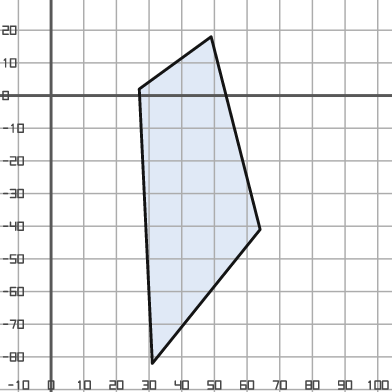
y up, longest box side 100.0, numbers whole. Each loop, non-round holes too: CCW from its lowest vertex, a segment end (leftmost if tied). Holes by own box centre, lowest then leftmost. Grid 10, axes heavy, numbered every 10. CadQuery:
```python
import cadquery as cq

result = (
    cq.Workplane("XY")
    .moveTo(31.0, -82.0)
    .lineTo(64.0, -41.0)
    .lineTo(49.0, 18.0)
    .lineTo(27.0, 2.0)
    .close()
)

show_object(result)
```